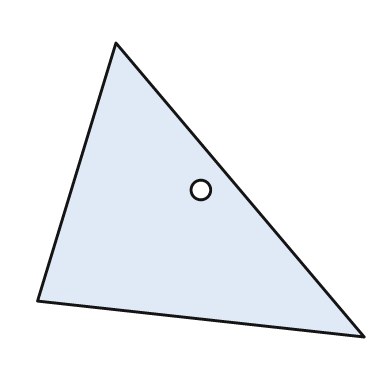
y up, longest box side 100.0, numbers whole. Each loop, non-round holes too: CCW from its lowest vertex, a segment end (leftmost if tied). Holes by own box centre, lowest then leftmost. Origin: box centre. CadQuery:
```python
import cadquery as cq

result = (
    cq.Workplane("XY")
    .moveTo(50.0, -45.0)
    .lineTo(-26.0, 45.0)
    .lineTo(-50.0, -34.0)
    .close()
    .moveTo(0.0, 0.0)
    .circle(3.0)
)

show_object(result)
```